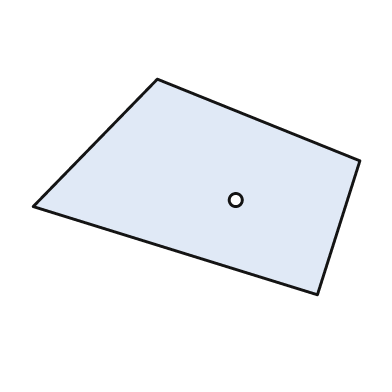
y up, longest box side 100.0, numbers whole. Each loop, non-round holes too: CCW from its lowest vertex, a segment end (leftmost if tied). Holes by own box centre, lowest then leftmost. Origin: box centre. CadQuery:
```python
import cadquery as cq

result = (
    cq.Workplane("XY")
    .moveTo(37.0, -33.0)
    .lineTo(50.0, 8.0)
    .lineTo(-12.0, 33.0)
    .lineTo(-50.0, -6.0)
    .close()
    .moveTo(12.0, -4.0)
    .circle(2.0)
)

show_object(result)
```